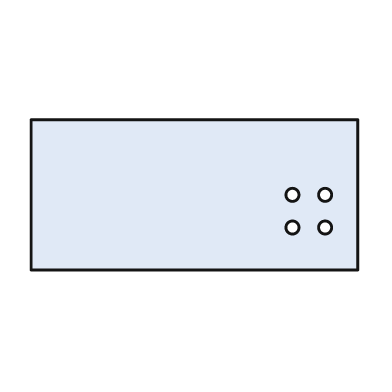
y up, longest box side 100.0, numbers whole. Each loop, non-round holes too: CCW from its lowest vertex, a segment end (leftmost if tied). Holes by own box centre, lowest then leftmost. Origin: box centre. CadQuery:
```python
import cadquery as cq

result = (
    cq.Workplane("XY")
    .moveTo(-50.0, -23.0)
    .lineTo(50.0, -23.0)
    .lineTo(50.0, 23.0)
    .lineTo(-50.0, 23.0)
    .close()
    .moveTo(30.0, -10.0)
    .circle(2.0)
    .moveTo(40.0, -10.0)
    .circle(2.0)
    .moveTo(30.0, 0.0)
    .circle(2.0)
    .moveTo(40.0, 0.0)
    .circle(2.0)
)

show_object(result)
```